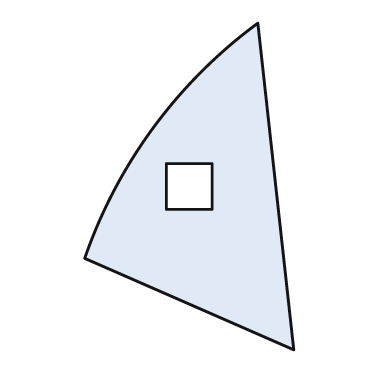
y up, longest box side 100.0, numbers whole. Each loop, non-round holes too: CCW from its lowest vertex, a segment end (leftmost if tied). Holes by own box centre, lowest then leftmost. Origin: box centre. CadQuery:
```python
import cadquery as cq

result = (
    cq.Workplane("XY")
    .moveTo(32.0, -50.0)
    .lineTo(21.0, 50.0)
    .threePointArc((-11.0, 18.0), (-32.0, -22.0))
    .close()
    .moveTo(-7.0, -7.0)
    .lineTo(7.0, -7.0)
    .lineTo(7.0, 7.0)
    .lineTo(-7.0, 7.0)
    .close()
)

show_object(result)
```